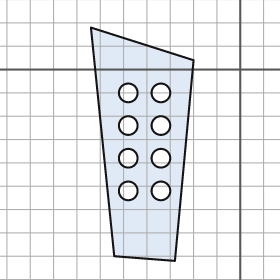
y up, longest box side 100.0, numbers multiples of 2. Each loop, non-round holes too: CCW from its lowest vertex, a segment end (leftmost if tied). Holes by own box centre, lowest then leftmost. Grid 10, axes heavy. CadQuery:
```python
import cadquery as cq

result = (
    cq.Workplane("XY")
    .moveTo(-28.0, -82.0)
    .lineTo(-20.0, 4.0)
    .lineTo(-64.0, 18.0)
    .lineTo(-54.0, -80.0)
    .close()
    .moveTo(-48.0, -52.0)
    .circle(4.0)
    .moveTo(-34.0, -52.0)
    .circle(4.0)
    .moveTo(-48.0, -38.0)
    .circle(4.0)
    .moveTo(-34.0, -38.0)
    .circle(4.0)
    .moveTo(-48.0, -24.0)
    .circle(4.0)
    .moveTo(-34.0, -24.0)
    .circle(4.0)
    .moveTo(-48.0, -10.0)
    .circle(4.0)
    .moveTo(-34.0, -10.0)
    .circle(4.0)
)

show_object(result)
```